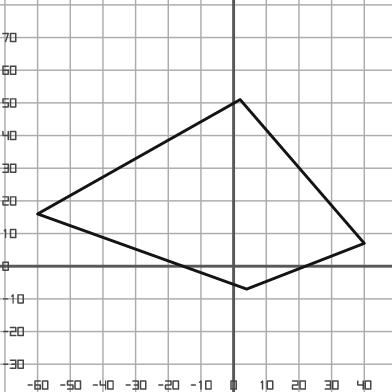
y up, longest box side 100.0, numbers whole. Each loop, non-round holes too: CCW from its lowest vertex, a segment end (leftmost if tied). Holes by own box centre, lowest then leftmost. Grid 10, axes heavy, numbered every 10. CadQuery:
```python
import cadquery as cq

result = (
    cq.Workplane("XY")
    .moveTo(4.0, -7.0)
    .lineTo(40.0, 7.0)
    .lineTo(2.0, 51.0)
    .lineTo(-60.0, 16.0)
    .close()
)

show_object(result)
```